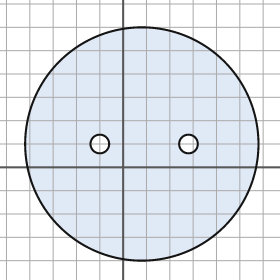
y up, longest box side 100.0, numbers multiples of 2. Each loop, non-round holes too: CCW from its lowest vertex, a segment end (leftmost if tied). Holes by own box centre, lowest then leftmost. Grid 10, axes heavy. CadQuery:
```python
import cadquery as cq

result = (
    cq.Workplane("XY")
    .moveTo(8.0, 10.0)
    .circle(50.0)
    .moveTo(-10.0, 10.0)
    .circle(4.0)
    .moveTo(28.0, 10.0)
    .circle(4.0)
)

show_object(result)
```